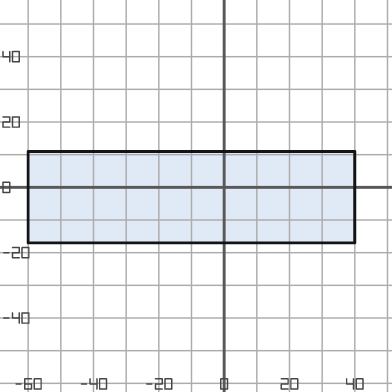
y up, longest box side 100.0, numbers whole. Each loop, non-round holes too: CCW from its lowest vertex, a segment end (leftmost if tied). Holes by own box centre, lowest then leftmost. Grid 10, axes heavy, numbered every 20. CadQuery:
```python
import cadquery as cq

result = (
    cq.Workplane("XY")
    .moveTo(-60.0, -17.0)
    .lineTo(40.0, -17.0)
    .lineTo(40.0, 11.0)
    .lineTo(-60.0, 11.0)
    .close()
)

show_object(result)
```